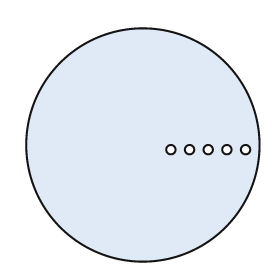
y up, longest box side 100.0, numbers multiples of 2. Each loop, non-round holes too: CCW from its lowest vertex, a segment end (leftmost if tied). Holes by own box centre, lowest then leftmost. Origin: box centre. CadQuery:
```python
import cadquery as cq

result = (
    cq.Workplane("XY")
    .moveTo(0.0, 0.0)
    .circle(50.0)
    .moveTo(12.0, -2.0)
    .circle(2.0)
    .moveTo(20.0, -2.0)
    .circle(2.0)
    .moveTo(28.0, -2.0)
    .circle(2.0)
    .moveTo(36.0, -2.0)
    .circle(2.0)
    .moveTo(44.0, -2.0)
    .circle(2.0)
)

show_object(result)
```